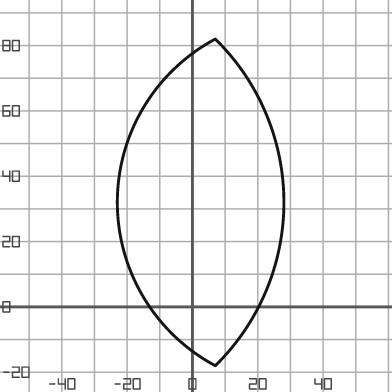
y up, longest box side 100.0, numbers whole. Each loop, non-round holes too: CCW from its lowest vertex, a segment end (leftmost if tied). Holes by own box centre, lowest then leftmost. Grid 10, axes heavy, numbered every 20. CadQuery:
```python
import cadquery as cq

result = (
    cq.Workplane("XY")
    .moveTo(7.0, -18.0)
    .threePointArc((28.0, 32.0), (7.0, 82.0))
    .threePointArc((-23.0, 32.0), (7.0, -18.0))
    .close()
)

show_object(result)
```